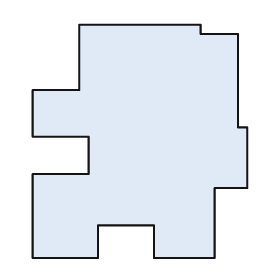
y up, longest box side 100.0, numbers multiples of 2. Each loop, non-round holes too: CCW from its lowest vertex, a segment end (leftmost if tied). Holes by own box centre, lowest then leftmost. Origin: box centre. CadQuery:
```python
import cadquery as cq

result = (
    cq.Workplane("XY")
    .moveTo(-46.0, -50.0)
    .lineTo(-18.0, -50.0)
    .lineTo(-18.0, -36.0)
    .lineTo(6.0, -36.0)
    .lineTo(6.0, -50.0)
    .lineTo(32.0, -50.0)
    .lineTo(32.0, -20.0)
    .lineTo(46.0, -20.0)
    .lineTo(46.0, 6.0)
    .lineTo(42.0, 6.0)
    .lineTo(42.0, 46.0)
    .lineTo(26.0, 46.0)
    .lineTo(26.0, 50.0)
    .lineTo(-26.0, 50.0)
    .lineTo(-26.0, 22.0)
    .lineTo(-46.0, 22.0)
    .lineTo(-46.0, 2.0)
    .lineTo(-22.0, 2.0)
    .lineTo(-22.0, -14.0)
    .lineTo(-46.0, -14.0)
    .close()
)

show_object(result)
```